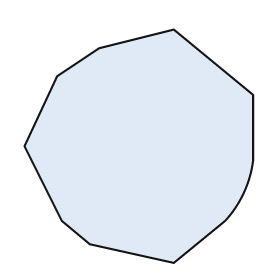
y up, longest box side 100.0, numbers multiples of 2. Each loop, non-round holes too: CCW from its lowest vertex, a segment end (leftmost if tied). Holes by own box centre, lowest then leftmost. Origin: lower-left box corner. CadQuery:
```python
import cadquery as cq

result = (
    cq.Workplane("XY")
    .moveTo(64.0, 0.0)
    .lineTo(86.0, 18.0)
    .threePointArc((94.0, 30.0), (98.0, 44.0))
    .lineTo(98.0, 72.0)
    .lineTo(64.0, 100.0)
    .lineTo(32.0, 92.0)
    .lineTo(14.0, 80.0)
    .lineTo(0.0, 50.0)
    .lineTo(16.0, 18.0)
    .lineTo(28.0, 8.0)
    .close()
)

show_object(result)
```